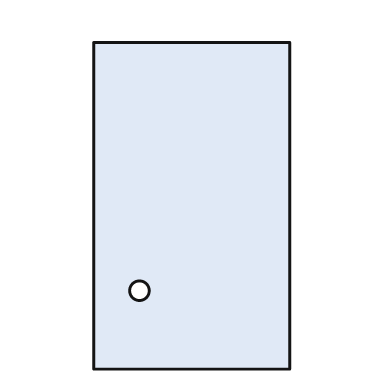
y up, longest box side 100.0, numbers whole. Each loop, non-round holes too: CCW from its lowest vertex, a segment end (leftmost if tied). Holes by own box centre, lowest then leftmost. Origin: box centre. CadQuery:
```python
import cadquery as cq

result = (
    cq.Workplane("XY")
    .moveTo(-30.0, -50.0)
    .lineTo(30.0, -50.0)
    .lineTo(30.0, 50.0)
    .lineTo(-30.0, 50.0)
    .close()
    .moveTo(-16.0, -26.0)
    .circle(3.0)
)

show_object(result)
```